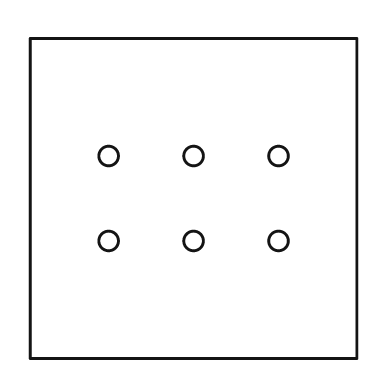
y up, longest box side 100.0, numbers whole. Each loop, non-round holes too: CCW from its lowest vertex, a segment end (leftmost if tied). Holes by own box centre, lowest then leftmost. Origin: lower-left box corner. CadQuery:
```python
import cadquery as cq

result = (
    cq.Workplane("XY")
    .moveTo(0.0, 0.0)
    .lineTo(100.0, 0.0)
    .lineTo(100.0, 98.0)
    .lineTo(0.0, 98.0)
    .close()
    .moveTo(24.0, 36.0)
    .circle(3.0)
    .moveTo(50.0, 36.0)
    .circle(3.0)
    .moveTo(76.0, 36.0)
    .circle(3.0)
    .moveTo(24.0, 62.0)
    .circle(3.0)
    .moveTo(50.0, 62.0)
    .circle(3.0)
    .moveTo(76.0, 62.0)
    .circle(3.0)
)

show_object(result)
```